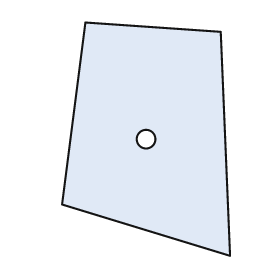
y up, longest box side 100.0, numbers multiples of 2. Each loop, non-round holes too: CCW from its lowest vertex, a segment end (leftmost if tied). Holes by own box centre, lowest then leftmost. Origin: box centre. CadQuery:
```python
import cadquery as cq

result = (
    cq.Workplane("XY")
    .moveTo(36.0, -50.0)
    .lineTo(32.0, 46.0)
    .lineTo(-26.0, 50.0)
    .lineTo(-36.0, -28.0)
    .close()
    .moveTo(0.0, 0.0)
    .circle(4.0)
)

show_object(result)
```